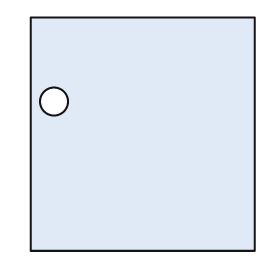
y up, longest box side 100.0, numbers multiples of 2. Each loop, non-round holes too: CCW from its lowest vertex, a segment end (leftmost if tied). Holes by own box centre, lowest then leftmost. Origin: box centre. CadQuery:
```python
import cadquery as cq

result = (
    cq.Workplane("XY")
    .moveTo(-48.0, -50.0)
    .lineTo(48.0, -50.0)
    .lineTo(48.0, 50.0)
    .lineTo(-48.0, 50.0)
    .close()
    .moveTo(-38.0, 14.0)
    .circle(6.0)
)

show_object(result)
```